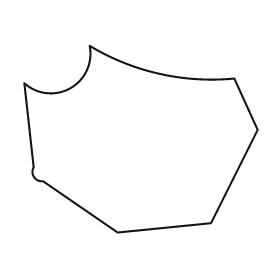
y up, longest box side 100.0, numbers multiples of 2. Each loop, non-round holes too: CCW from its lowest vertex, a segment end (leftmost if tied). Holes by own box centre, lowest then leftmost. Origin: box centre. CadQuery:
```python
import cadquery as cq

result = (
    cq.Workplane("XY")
    .moveTo(-10.0, -40.0)
    .lineTo(30.0, -36.0)
    .lineTo(50.0, 4.0)
    .lineTo(40.0, 26.0)
    .threePointArc((8.0, 28.0), (-22.0, 40.0))
    .threePointArc((-30.0, 22.0), (-50.0, 24.0))
    .lineTo(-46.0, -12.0)
    .threePointArc((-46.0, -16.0), (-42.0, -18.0))
    .close()
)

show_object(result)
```